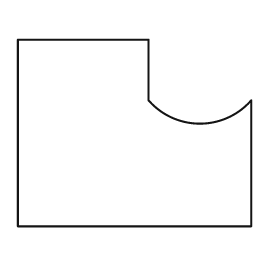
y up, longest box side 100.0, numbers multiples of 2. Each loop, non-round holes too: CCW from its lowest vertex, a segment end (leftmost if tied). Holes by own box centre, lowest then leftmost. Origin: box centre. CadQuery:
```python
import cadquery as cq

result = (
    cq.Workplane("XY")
    .moveTo(-50.0, -40.0)
    .lineTo(50.0, -40.0)
    .lineTo(50.0, 14.0)
    .threePointArc((28.0, 4.0), (6.0, 14.0))
    .lineTo(6.0, 40.0)
    .lineTo(-50.0, 40.0)
    .close()
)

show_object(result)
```